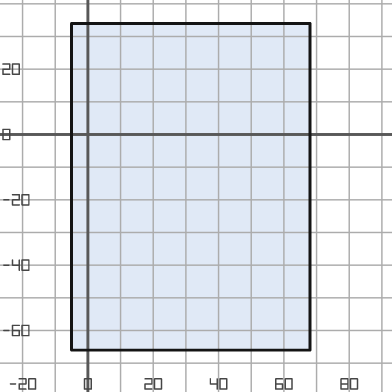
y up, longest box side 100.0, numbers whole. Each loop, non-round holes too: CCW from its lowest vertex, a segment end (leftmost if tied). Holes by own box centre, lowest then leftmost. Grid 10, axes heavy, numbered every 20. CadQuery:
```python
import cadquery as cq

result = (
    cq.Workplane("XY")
    .moveTo(-5.0, -66.0)
    .lineTo(68.0, -66.0)
    .lineTo(68.0, 34.0)
    .lineTo(-5.0, 34.0)
    .close()
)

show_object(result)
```